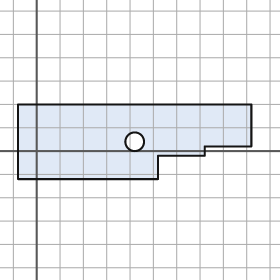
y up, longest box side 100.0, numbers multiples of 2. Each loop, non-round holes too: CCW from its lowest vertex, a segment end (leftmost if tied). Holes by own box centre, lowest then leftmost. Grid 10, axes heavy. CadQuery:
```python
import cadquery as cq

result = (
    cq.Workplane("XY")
    .moveTo(-8.0, -12.0)
    .lineTo(52.0, -12.0)
    .lineTo(52.0, -2.0)
    .lineTo(72.0, -2.0)
    .lineTo(72.0, 2.0)
    .lineTo(92.0, 2.0)
    .lineTo(92.0, 20.0)
    .lineTo(-8.0, 20.0)
    .close()
    .moveTo(42.0, 4.0)
    .circle(4.0)
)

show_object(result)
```